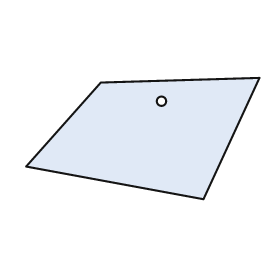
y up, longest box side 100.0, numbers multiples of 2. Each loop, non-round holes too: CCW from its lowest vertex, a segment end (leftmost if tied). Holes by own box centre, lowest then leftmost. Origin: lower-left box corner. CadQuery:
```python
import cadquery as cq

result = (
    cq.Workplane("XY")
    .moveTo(76.0, 0.0)
    .lineTo(100.0, 52.0)
    .lineTo(32.0, 50.0)
    .lineTo(0.0, 14.0)
    .close()
    .moveTo(58.0, 42.0)
    .circle(2.0)
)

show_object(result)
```